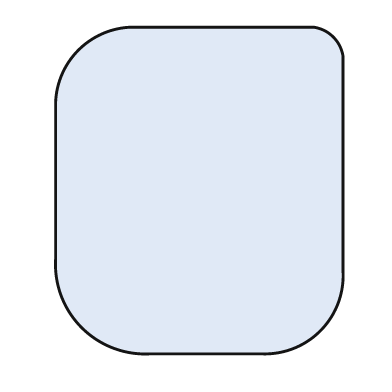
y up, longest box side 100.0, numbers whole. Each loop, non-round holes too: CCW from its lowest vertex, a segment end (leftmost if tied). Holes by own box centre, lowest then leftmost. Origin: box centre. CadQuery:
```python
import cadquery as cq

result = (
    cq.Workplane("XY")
    .moveTo(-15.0, -50.0)
    .lineTo(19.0, -50.0)
    .threePointArc((37.0, -43.0), (44.0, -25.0))
    .lineTo(44.0, 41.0)
    .threePointArc((41.0, 47.0), (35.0, 50.0))
    .lineTo(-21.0, 50.0)
    .threePointArc((-37.0, 43.0), (-44.0, 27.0))
    .lineTo(-44.0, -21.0)
    .threePointArc((-36.0, -42.0), (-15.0, -50.0))
    .close()
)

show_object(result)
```